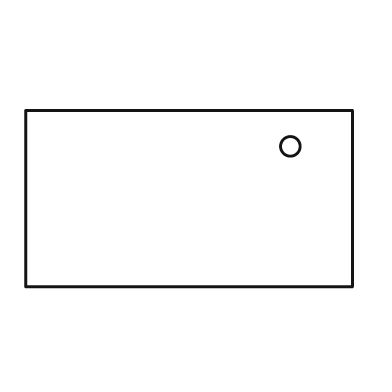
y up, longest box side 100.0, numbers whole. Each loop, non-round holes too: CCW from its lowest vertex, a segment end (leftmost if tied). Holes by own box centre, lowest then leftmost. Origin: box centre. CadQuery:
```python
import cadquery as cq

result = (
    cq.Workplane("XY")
    .moveTo(-50.0, -27.0)
    .lineTo(50.0, -27.0)
    .lineTo(50.0, 27.0)
    .lineTo(-50.0, 27.0)
    .close()
    .moveTo(31.0, 16.0)
    .circle(3.0)
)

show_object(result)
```